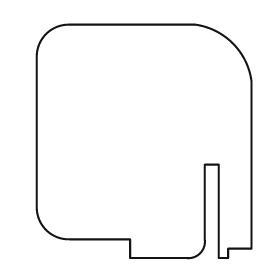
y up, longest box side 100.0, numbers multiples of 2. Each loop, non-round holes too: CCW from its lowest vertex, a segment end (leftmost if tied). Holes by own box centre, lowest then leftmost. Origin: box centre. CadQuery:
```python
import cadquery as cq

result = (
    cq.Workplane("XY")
    .moveTo(-6.0, -50.0)
    .lineTo(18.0, -50.0)
    .threePointArc((24.0, -48.0), (26.0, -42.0))
    .lineTo(26.0, -10.0)
    .lineTo(32.0, -10.0)
    .lineTo(32.0, -50.0)
    .lineTo(36.0, -50.0)
    .lineTo(36.0, -46.0)
    .lineTo(46.0, -46.0)
    .lineTo(46.0, 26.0)
    .threePointArc((38.0, 42.0), (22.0, 50.0))
    .lineTo(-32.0, 50.0)
    .threePointArc((-42.0, 46.0), (-46.0, 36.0))
    .lineTo(-46.0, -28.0)
    .threePointArc((-42.0, -38.0), (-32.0, -42.0))
    .lineTo(-6.0, -42.0)
    .close()
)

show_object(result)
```